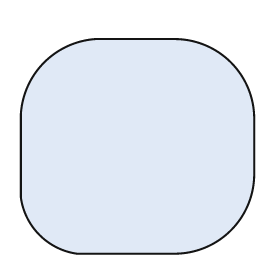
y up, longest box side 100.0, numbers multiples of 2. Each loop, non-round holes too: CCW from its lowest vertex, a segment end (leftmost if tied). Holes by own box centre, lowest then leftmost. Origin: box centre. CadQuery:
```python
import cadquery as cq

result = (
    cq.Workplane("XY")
    .moveTo(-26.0, -46.0)
    .lineTo(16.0, -46.0)
    .threePointArc((40.0, -36.0), (50.0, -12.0))
    .lineTo(50.0, 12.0)
    .threePointArc((40.0, 36.0), (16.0, 46.0))
    .lineTo(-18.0, 46.0)
    .threePointArc((-40.0, 36.0), (-50.0, 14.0))
    .lineTo(-50.0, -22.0)
    .threePointArc((-42.0, -38.0), (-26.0, -46.0))
    .close()
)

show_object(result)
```